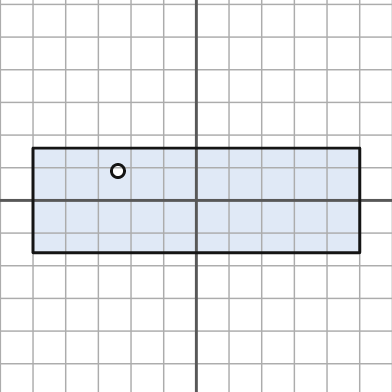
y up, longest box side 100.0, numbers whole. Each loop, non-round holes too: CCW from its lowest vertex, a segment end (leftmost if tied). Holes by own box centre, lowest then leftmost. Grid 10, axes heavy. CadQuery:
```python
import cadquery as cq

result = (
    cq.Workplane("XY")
    .moveTo(-50.0, -16.0)
    .lineTo(50.0, -16.0)
    .lineTo(50.0, 16.0)
    .lineTo(-50.0, 16.0)
    .close()
    .moveTo(-24.0, 9.0)
    .circle(2.0)
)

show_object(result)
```